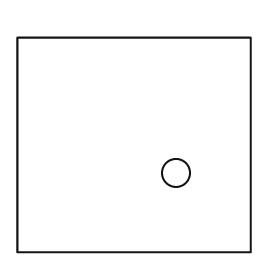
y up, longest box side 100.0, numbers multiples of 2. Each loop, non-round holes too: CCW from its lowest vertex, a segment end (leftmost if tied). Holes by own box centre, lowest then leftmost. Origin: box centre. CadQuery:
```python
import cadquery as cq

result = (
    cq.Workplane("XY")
    .moveTo(-50.0, -46.0)
    .lineTo(50.0, -46.0)
    .lineTo(50.0, 46.0)
    .lineTo(-50.0, 46.0)
    .close()
    .moveTo(18.0, -12.0)
    .circle(6.0)
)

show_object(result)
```